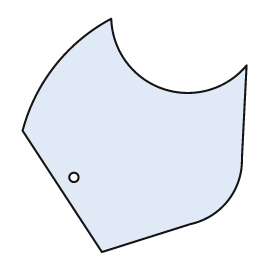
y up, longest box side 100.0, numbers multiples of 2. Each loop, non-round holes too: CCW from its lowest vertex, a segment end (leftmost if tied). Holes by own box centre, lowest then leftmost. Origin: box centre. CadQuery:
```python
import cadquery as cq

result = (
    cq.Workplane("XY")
    .moveTo(-14.0, -50.0)
    .lineTo(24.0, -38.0)
    .threePointArc((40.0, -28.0), (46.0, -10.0))
    .lineTo(48.0, 30.0)
    .threePointArc((12.0, 20.0), (-10.0, 50.0))
    .threePointArc((-34.0, 30.0), (-48.0, 2.0))
    .close()
    .moveTo(-26.0, -18.0)
    .circle(2.0)
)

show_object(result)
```